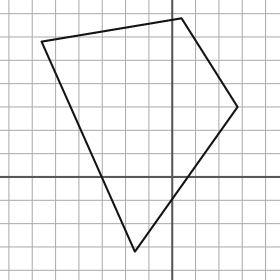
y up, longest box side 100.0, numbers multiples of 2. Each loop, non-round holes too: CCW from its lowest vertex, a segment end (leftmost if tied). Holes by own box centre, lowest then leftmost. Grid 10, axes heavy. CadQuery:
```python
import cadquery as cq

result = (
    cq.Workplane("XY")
    .moveTo(-16.0, -32.0)
    .lineTo(28.0, 30.0)
    .lineTo(4.0, 68.0)
    .lineTo(-56.0, 58.0)
    .close()
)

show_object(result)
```